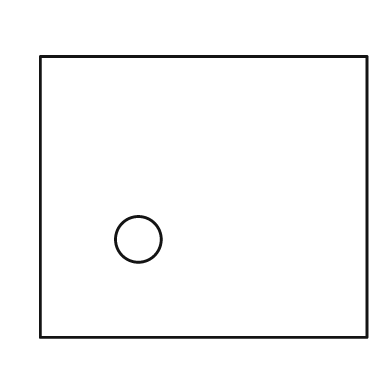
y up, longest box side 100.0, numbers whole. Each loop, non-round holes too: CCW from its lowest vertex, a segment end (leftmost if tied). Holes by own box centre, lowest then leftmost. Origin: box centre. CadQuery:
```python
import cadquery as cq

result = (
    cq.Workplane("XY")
    .moveTo(-50.0, -43.0)
    .lineTo(50.0, -43.0)
    .lineTo(50.0, 43.0)
    .lineTo(-50.0, 43.0)
    .close()
    .moveTo(-20.0, -13.0)
    .circle(7.0)
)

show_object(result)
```